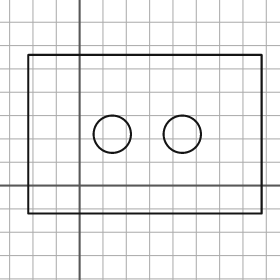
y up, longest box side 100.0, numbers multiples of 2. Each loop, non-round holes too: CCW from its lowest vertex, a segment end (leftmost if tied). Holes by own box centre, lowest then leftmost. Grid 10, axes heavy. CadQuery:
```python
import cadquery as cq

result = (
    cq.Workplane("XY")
    .moveTo(-22.0, -12.0)
    .lineTo(78.0, -12.0)
    .lineTo(78.0, 56.0)
    .lineTo(-22.0, 56.0)
    .close()
    .moveTo(14.0, 22.0)
    .circle(8.0)
    .moveTo(44.0, 22.0)
    .circle(8.0)
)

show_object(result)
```